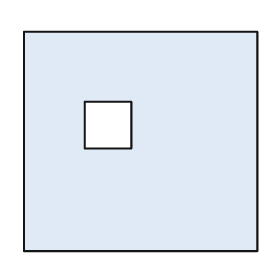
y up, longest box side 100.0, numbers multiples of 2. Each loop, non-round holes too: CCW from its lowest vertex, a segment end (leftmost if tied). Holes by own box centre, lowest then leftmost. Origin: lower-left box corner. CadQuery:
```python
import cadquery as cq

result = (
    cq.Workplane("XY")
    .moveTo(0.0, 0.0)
    .lineTo(100.0, 0.0)
    .lineTo(100.0, 94.0)
    .lineTo(0.0, 94.0)
    .close()
    .moveTo(26.0, 44.0)
    .lineTo(46.0, 44.0)
    .lineTo(46.0, 64.0)
    .lineTo(26.0, 64.0)
    .close()
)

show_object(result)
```